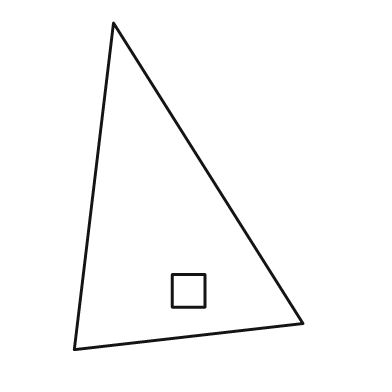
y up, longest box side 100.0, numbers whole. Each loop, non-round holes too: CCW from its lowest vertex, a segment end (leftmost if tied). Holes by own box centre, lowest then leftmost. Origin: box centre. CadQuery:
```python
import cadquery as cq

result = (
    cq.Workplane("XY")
    .moveTo(-35.0, -50.0)
    .lineTo(35.0, -42.0)
    .lineTo(-23.0, 50.0)
    .close()
    .moveTo(-5.0, -37.0)
    .lineTo(5.0, -37.0)
    .lineTo(5.0, -27.0)
    .lineTo(-5.0, -27.0)
    .close()
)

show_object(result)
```